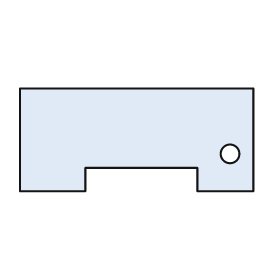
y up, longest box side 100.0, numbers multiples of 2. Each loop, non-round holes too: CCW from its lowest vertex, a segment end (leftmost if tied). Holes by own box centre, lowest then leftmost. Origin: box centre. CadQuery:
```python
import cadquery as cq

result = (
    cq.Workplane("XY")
    .moveTo(-50.0, -22.0)
    .lineTo(-22.0, -22.0)
    .lineTo(-22.0, -12.0)
    .lineTo(26.0, -12.0)
    .lineTo(26.0, -22.0)
    .lineTo(50.0, -22.0)
    .lineTo(50.0, 22.0)
    .lineTo(-50.0, 22.0)
    .close()
    .moveTo(40.0, -6.0)
    .circle(4.0)
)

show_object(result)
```